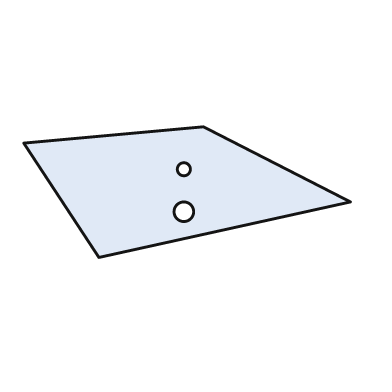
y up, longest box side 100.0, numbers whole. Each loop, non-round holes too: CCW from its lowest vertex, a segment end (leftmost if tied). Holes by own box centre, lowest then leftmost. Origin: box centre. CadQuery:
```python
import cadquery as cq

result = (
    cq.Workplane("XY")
    .moveTo(-27.0, -20.0)
    .lineTo(50.0, -3.0)
    .lineTo(5.0, 20.0)
    .lineTo(-50.0, 15.0)
    .close()
    .moveTo(-1.0, -6.0)
    .circle(3.0)
    .moveTo(-1.0, 7.0)
    .circle(2.0)
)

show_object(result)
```